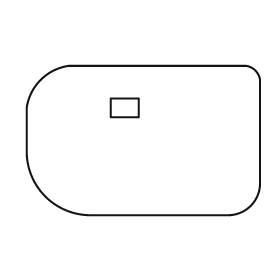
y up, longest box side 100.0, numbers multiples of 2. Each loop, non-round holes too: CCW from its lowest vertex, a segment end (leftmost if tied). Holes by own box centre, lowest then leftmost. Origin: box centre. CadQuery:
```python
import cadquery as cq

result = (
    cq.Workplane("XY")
    .moveTo(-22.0, -32.0)
    .lineTo(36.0, -32.0)
    .threePointArc((46.0, -28.0), (50.0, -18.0))
    .lineTo(50.0, 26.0)
    .threePointArc((48.0, 30.0), (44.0, 32.0))
    .lineTo(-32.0, 32.0)
    .threePointArc((-44.0, 26.0), (-50.0, 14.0))
    .lineTo(-50.0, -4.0)
    .threePointArc((-42.0, -24.0), (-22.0, -32.0))
    .close()
    .moveTo(-14.0, 10.0)
    .lineTo(-2.0, 10.0)
    .lineTo(-2.0, 18.0)
    .lineTo(-14.0, 18.0)
    .close()
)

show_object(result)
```